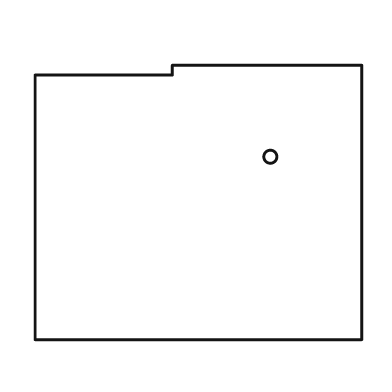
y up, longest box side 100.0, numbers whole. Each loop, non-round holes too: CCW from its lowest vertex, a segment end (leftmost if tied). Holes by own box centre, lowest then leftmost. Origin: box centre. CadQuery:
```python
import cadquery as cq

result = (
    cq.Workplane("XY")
    .moveTo(-50.0, -42.0)
    .lineTo(50.0, -42.0)
    .lineTo(50.0, 42.0)
    .lineTo(-8.0, 42.0)
    .lineTo(-8.0, 39.0)
    .lineTo(-50.0, 39.0)
    .close()
    .moveTo(22.0, 14.0)
    .circle(2.0)
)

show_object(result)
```